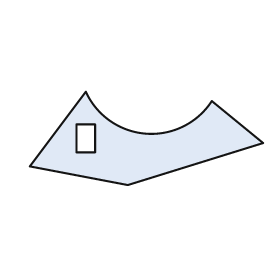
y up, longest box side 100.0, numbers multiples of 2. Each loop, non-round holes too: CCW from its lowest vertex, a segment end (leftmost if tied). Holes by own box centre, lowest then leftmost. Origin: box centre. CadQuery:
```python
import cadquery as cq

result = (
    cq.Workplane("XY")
    .moveTo(-8.0, -20.0)
    .lineTo(50.0, -2.0)
    .lineTo(28.0, 16.0)
    .threePointArc((0.0, 2.0), (-26.0, 20.0))
    .lineTo(-50.0, -12.0)
    .close()
    .moveTo(-30.0, -6.0)
    .lineTo(-22.0, -6.0)
    .lineTo(-22.0, 6.0)
    .lineTo(-30.0, 6.0)
    .close()
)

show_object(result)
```